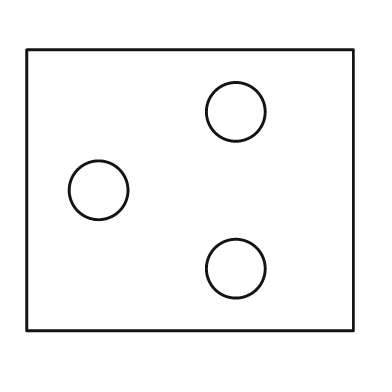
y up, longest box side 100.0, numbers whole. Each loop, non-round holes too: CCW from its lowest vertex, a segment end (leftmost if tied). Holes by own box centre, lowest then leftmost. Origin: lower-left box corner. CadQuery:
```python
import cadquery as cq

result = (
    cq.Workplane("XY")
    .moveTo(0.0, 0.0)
    .lineTo(100.0, 0.0)
    .lineTo(100.0, 86.0)
    .lineTo(0.0, 86.0)
    .close()
    .moveTo(64.0, 19.0)
    .circle(9.0)
    .moveTo(22.0, 43.0)
    .circle(9.0)
    .moveTo(64.0, 67.0)
    .circle(9.0)
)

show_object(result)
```